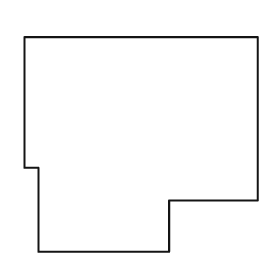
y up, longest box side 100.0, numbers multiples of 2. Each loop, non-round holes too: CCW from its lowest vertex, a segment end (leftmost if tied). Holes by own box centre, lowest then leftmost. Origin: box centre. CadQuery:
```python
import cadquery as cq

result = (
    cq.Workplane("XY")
    .moveTo(-44.0, -46.0)
    .lineTo(12.0, -46.0)
    .lineTo(12.0, -24.0)
    .lineTo(50.0, -24.0)
    .lineTo(50.0, 46.0)
    .lineTo(-50.0, 46.0)
    .lineTo(-50.0, -10.0)
    .lineTo(-44.0, -10.0)
    .close()
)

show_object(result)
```